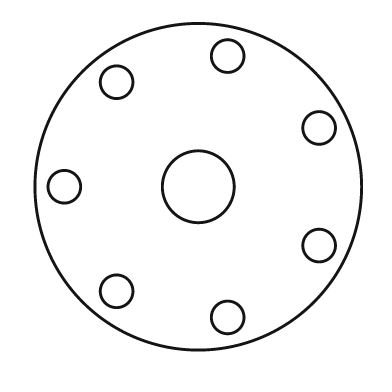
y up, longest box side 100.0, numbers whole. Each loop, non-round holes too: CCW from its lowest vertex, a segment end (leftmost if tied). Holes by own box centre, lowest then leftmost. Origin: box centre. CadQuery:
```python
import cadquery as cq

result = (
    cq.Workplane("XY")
    .moveTo(0.0, 0.0)
    .circle(50.0)
    .moveTo(9.0, -40.0)
    .circle(5.0)
    .moveTo(-25.0, -32.0)
    .circle(5.0)
    .moveTo(37.0, -18.0)
    .circle(5.0)
    .moveTo(-41.0, 0.0)
    .circle(5.0)
    .moveTo(0.0, 0.0)
    .circle(11.0)
    .moveTo(37.0, 18.0)
    .circle(5.0)
    .moveTo(-25.0, 32.0)
    .circle(5.0)
    .moveTo(9.0, 40.0)
    .circle(5.0)
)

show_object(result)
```